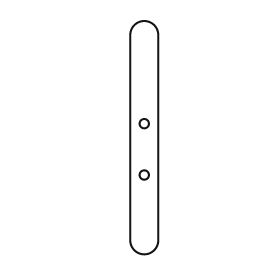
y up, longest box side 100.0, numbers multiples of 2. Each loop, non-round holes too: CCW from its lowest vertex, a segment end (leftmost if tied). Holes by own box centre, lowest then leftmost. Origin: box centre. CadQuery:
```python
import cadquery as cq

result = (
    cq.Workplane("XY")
    .moveTo(-6.0, -44.0)
    .threePointArc((0.0, -50.0), (6.0, -44.0))
    .lineTo(6.0, 44.0)
    .threePointArc((0.0, 50.0), (-6.0, 44.0))
    .close()
    .moveTo(0.0, -16.0)
    .circle(2.0)
    .moveTo(0.0, 6.0)
    .circle(2.0)
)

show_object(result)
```